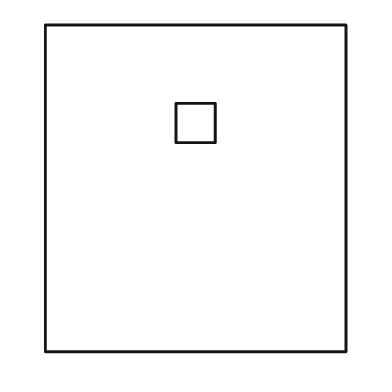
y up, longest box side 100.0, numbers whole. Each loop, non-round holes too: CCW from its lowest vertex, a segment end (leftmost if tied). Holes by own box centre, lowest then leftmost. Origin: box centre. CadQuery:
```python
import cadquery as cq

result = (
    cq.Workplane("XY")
    .moveTo(-46.0, -50.0)
    .lineTo(46.0, -50.0)
    .lineTo(46.0, 50.0)
    .lineTo(-46.0, 50.0)
    .close()
    .moveTo(-6.0, 14.0)
    .lineTo(6.0, 14.0)
    .lineTo(6.0, 26.0)
    .lineTo(-6.0, 26.0)
    .close()
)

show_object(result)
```